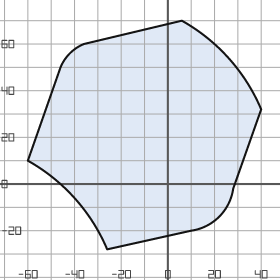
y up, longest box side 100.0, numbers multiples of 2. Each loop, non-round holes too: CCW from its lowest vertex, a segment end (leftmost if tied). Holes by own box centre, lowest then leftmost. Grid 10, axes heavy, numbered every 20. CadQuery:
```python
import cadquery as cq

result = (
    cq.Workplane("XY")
    .moveTo(-26.0, -28.0)
    .lineTo(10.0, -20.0)
    .threePointArc((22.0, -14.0), (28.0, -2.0))
    .lineTo(40.0, 32.0)
    .threePointArc((26.0, 54.0), (6.0, 70.0))
    .lineTo(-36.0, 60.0)
    .threePointArc((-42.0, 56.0), (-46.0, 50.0))
    .lineTo(-60.0, 10.0)
    .threePointArc((-40.0, -6.0), (-26.0, -28.0))
    .close()
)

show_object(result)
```